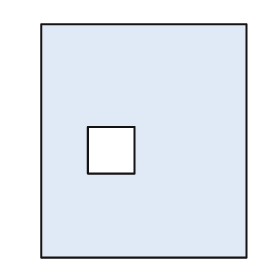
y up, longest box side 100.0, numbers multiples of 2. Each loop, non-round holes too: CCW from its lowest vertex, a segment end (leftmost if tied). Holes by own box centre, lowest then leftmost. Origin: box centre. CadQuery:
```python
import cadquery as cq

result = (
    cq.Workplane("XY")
    .moveTo(-44.0, -50.0)
    .lineTo(44.0, -50.0)
    .lineTo(44.0, 50.0)
    .lineTo(-44.0, 50.0)
    .close()
    .moveTo(-24.0, -14.0)
    .lineTo(-4.0, -14.0)
    .lineTo(-4.0, 6.0)
    .lineTo(-24.0, 6.0)
    .close()
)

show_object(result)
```